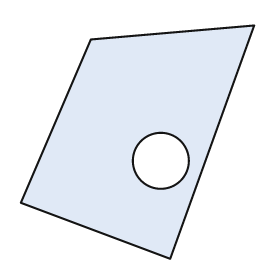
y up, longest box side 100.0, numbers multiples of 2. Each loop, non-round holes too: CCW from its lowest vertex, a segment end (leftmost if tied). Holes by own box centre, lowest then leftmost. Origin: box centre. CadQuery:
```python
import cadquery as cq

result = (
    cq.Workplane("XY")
    .moveTo(14.0, -50.0)
    .lineTo(50.0, 50.0)
    .lineTo(-20.0, 44.0)
    .lineTo(-50.0, -26.0)
    .close()
    .moveTo(10.0, -8.0)
    .circle(12.0)
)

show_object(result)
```